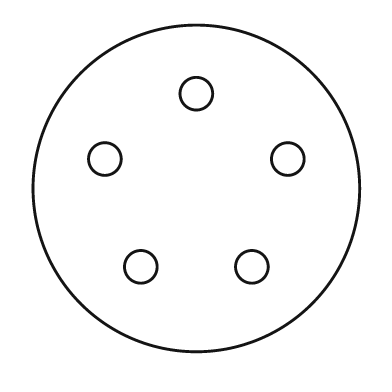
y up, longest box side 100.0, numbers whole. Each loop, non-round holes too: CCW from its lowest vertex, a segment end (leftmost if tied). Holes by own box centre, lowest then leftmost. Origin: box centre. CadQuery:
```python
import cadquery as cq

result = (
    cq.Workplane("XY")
    .moveTo(0.0, 0.0)
    .circle(50.0)
    .moveTo(-17.0, -24.0)
    .circle(5.0)
    .moveTo(17.0, -24.0)
    .circle(5.0)
    .moveTo(-28.0, 9.0)
    .circle(5.0)
    .moveTo(28.0, 9.0)
    .circle(5.0)
    .moveTo(0.0, 29.0)
    .circle(5.0)
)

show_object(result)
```